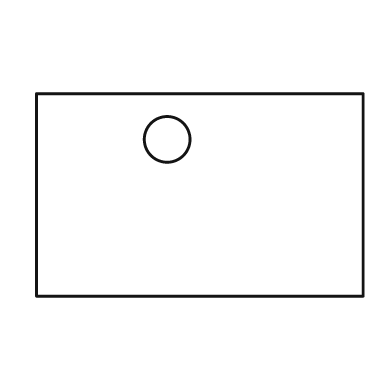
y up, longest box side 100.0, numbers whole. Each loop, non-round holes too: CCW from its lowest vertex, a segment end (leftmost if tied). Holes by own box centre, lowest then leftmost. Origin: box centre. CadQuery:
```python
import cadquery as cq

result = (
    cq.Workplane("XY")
    .moveTo(-50.0, -31.0)
    .lineTo(50.0, -31.0)
    .lineTo(50.0, 31.0)
    .lineTo(-50.0, 31.0)
    .close()
    .moveTo(-10.0, 17.0)
    .circle(7.0)
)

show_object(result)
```